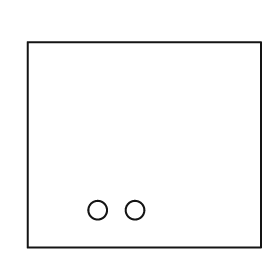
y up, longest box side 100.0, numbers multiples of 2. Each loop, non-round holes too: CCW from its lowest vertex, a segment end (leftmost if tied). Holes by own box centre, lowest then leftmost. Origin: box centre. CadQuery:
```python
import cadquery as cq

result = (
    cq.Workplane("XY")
    .moveTo(-50.0, -44.0)
    .lineTo(50.0, -44.0)
    .lineTo(50.0, 44.0)
    .lineTo(-50.0, 44.0)
    .close()
    .moveTo(-20.0, -28.0)
    .circle(4.0)
    .moveTo(-4.0, -28.0)
    .circle(4.0)
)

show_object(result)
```